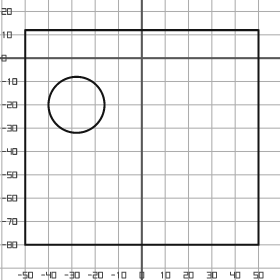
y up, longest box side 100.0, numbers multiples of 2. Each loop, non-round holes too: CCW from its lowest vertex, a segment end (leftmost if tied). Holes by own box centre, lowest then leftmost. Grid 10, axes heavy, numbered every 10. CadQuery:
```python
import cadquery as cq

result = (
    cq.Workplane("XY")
    .moveTo(-50.0, -80.0)
    .lineTo(50.0, -80.0)
    .lineTo(50.0, 12.0)
    .lineTo(-50.0, 12.0)
    .close()
    .moveTo(-28.0, -20.0)
    .circle(12.0)
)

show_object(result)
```